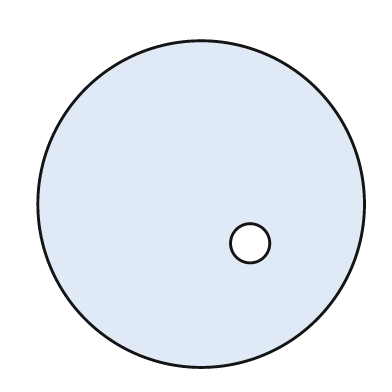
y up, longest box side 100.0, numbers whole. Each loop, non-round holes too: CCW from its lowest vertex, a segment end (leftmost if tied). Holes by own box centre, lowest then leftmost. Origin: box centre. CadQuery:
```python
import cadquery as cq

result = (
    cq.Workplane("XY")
    .moveTo(0.0, 0.0)
    .circle(50.0)
    .moveTo(15.0, -12.0)
    .circle(6.0)
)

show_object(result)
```